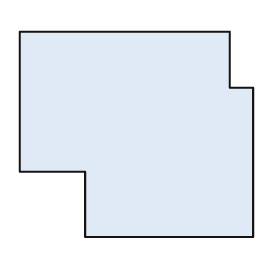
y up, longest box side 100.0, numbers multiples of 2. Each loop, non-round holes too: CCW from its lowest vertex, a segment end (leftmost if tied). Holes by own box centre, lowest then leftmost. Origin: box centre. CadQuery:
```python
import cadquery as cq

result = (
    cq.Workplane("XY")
    .moveTo(-22.0, -44.0)
    .lineTo(50.0, -44.0)
    .lineTo(50.0, 20.0)
    .lineTo(40.0, 20.0)
    .lineTo(40.0, 44.0)
    .lineTo(-50.0, 44.0)
    .lineTo(-50.0, -16.0)
    .lineTo(-22.0, -16.0)
    .close()
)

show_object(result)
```